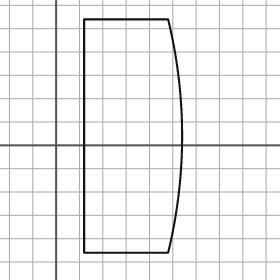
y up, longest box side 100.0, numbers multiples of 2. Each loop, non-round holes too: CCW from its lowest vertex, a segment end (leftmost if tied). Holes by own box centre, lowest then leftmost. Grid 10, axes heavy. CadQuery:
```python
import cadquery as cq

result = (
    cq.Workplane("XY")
    .moveTo(12.0, -46.0)
    .lineTo(48.0, -46.0)
    .threePointArc((54.0, 4.0), (48.0, 54.0))
    .lineTo(12.0, 54.0)
    .close()
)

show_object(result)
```